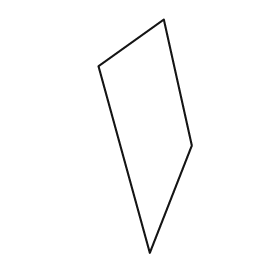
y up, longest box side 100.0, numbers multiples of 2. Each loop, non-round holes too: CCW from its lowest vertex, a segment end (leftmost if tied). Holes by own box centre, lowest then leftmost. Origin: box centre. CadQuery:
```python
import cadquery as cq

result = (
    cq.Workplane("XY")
    .moveTo(2.0, -50.0)
    .lineTo(20.0, -4.0)
    .lineTo(8.0, 50.0)
    .lineTo(-20.0, 30.0)
    .close()
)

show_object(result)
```